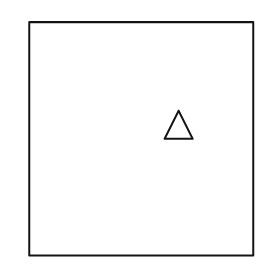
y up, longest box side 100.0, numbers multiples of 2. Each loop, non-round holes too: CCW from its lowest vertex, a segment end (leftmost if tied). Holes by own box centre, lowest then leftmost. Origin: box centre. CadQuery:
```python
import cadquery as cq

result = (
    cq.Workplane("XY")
    .moveTo(-48.0, -50.0)
    .lineTo(48.0, -50.0)
    .lineTo(48.0, 50.0)
    .lineTo(-48.0, 50.0)
    .close()
    .moveTo(10.0, 0.0)
    .lineTo(22.0, 0.0)
    .lineTo(16.0, 12.0)
    .close()
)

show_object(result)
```